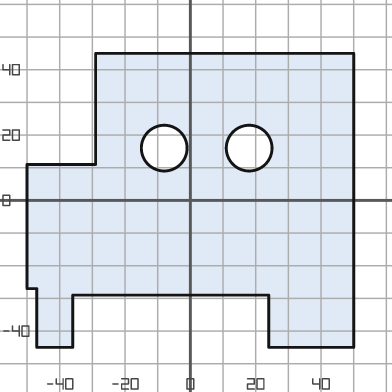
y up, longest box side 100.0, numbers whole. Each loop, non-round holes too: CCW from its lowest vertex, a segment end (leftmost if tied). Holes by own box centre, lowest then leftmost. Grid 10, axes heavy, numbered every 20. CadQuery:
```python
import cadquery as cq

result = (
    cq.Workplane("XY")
    .moveTo(-47.0, -45.0)
    .lineTo(-36.0, -45.0)
    .lineTo(-36.0, -29.0)
    .lineTo(24.0, -29.0)
    .lineTo(24.0, -45.0)
    .lineTo(50.0, -45.0)
    .lineTo(50.0, 45.0)
    .lineTo(-29.0, 45.0)
    .lineTo(-29.0, 11.0)
    .lineTo(-50.0, 11.0)
    .lineTo(-50.0, -27.0)
    .lineTo(-47.0, -27.0)
    .close()
    .moveTo(-8.0, 16.0)
    .circle(7.0)
    .moveTo(18.0, 16.0)
    .circle(7.0)
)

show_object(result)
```